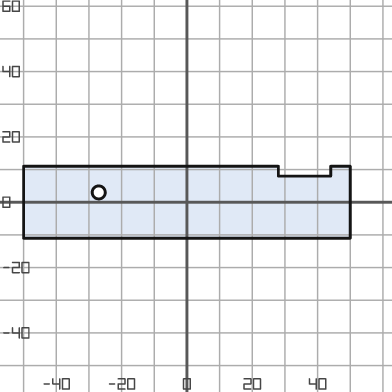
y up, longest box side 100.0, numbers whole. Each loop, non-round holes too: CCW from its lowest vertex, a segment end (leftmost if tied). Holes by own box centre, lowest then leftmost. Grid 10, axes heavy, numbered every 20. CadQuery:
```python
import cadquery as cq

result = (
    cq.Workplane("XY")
    .moveTo(-50.0, -11.0)
    .lineTo(50.0, -11.0)
    .lineTo(50.0, 11.0)
    .lineTo(44.0, 11.0)
    .lineTo(44.0, 8.0)
    .lineTo(28.0, 8.0)
    .lineTo(28.0, 11.0)
    .lineTo(-50.0, 11.0)
    .close()
    .moveTo(-27.0, 3.0)
    .circle(2.0)
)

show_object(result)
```